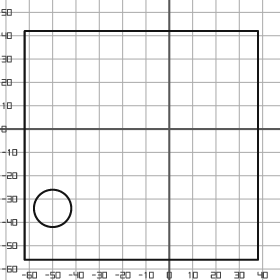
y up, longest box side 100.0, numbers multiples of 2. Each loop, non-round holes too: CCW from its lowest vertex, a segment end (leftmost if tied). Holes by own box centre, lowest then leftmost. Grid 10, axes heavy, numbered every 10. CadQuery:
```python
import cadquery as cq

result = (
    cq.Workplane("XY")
    .moveTo(-62.0, -56.0)
    .lineTo(38.0, -56.0)
    .lineTo(38.0, 42.0)
    .lineTo(-62.0, 42.0)
    .close()
    .moveTo(-50.0, -34.0)
    .circle(8.0)
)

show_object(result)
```